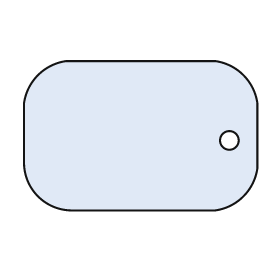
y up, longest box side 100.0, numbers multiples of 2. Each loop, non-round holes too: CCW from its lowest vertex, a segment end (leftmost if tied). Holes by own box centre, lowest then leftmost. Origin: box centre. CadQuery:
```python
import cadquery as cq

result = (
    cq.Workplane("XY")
    .moveTo(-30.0, -32.0)
    .lineTo(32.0, -32.0)
    .threePointArc((44.0, -26.0), (50.0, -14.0))
    .lineTo(50.0, 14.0)
    .threePointArc((44.0, 26.0), (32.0, 32.0))
    .lineTo(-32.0, 32.0)
    .threePointArc((-44.0, 26.0), (-50.0, 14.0))
    .lineTo(-50.0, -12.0)
    .threePointArc((-44.0, -26.0), (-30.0, -32.0))
    .close()
    .moveTo(38.0, -2.0)
    .circle(4.0)
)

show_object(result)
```